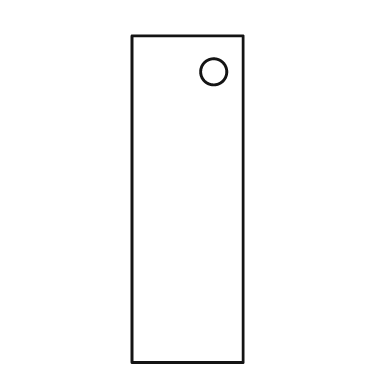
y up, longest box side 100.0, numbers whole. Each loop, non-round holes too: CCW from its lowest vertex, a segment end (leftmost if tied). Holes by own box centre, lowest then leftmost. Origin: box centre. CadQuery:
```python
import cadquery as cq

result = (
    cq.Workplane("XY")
    .moveTo(-17.0, -50.0)
    .lineTo(17.0, -50.0)
    .lineTo(17.0, 50.0)
    .lineTo(-17.0, 50.0)
    .close()
    .moveTo(8.0, 39.0)
    .circle(4.0)
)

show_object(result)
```